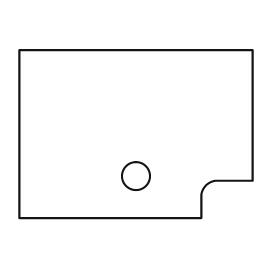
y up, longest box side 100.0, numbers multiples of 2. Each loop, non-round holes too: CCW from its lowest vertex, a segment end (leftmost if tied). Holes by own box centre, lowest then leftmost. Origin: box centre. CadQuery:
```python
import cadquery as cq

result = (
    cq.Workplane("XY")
    .moveTo(-50.0, -36.0)
    .lineTo(28.0, -36.0)
    .lineTo(28.0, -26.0)
    .threePointArc((30.0, -22.0), (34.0, -20.0))
    .lineTo(50.0, -20.0)
    .lineTo(50.0, 36.0)
    .lineTo(-50.0, 36.0)
    .close()
    .moveTo(0.0, -18.0)
    .circle(6.0)
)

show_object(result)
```